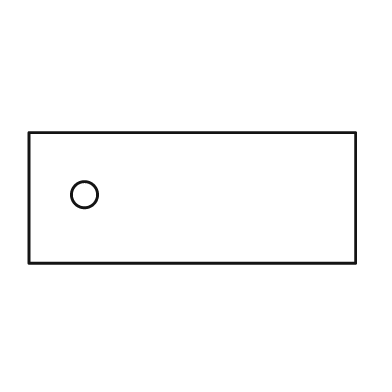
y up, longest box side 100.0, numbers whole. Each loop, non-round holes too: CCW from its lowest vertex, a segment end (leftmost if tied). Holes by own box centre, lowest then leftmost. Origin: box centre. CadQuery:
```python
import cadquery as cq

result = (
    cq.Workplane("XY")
    .moveTo(-50.0, -20.0)
    .lineTo(50.0, -20.0)
    .lineTo(50.0, 20.0)
    .lineTo(-50.0, 20.0)
    .close()
    .moveTo(-33.0, 1.0)
    .circle(4.0)
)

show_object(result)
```